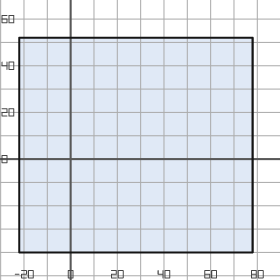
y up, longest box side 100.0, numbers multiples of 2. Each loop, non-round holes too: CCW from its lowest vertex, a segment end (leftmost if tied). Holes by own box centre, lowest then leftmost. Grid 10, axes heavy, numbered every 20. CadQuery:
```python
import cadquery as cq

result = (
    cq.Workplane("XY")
    .moveTo(-22.0, -40.0)
    .lineTo(78.0, -40.0)
    .lineTo(78.0, 52.0)
    .lineTo(-22.0, 52.0)
    .close()
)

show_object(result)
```